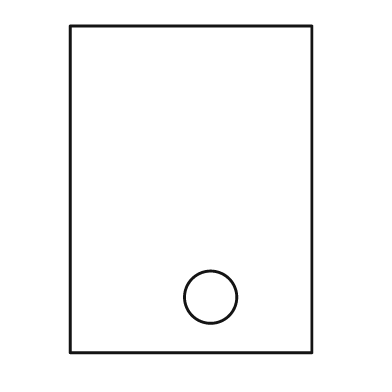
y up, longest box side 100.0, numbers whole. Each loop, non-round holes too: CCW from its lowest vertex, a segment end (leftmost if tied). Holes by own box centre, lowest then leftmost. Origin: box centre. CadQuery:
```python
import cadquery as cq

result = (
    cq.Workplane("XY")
    .moveTo(-37.0, -50.0)
    .lineTo(37.0, -50.0)
    .lineTo(37.0, 50.0)
    .lineTo(-37.0, 50.0)
    .close()
    .moveTo(6.0, -33.0)
    .circle(8.0)
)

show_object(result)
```